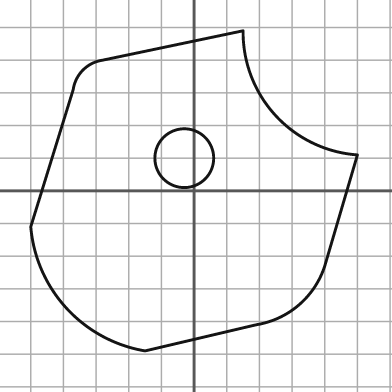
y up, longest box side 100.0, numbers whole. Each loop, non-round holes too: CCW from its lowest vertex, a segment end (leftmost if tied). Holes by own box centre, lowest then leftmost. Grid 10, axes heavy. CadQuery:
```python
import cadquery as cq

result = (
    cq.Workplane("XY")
    .moveTo(-15.0, -49.0)
    .lineTo(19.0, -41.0)
    .threePointArc((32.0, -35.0), (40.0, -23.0))
    .lineTo(50.0, 11.0)
    .threePointArc((25.0, 23.0), (15.0, 49.0))
    .lineTo(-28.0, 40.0)
    .threePointArc((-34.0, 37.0), (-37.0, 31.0))
    .lineTo(-50.0, -11.0)
    .threePointArc((-39.0, -36.0), (-15.0, -49.0))
    .close()
    .moveTo(-3.0, 10.0)
    .circle(9.0)
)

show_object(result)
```